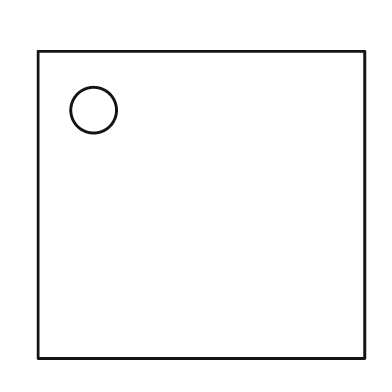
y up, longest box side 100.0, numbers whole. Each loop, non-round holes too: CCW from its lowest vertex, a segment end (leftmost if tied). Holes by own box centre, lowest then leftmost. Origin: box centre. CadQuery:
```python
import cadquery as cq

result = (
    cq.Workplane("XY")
    .moveTo(-50.0, -47.0)
    .lineTo(50.0, -47.0)
    .lineTo(50.0, 47.0)
    .lineTo(-50.0, 47.0)
    .close()
    .moveTo(-33.0, 29.0)
    .circle(7.0)
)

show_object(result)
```